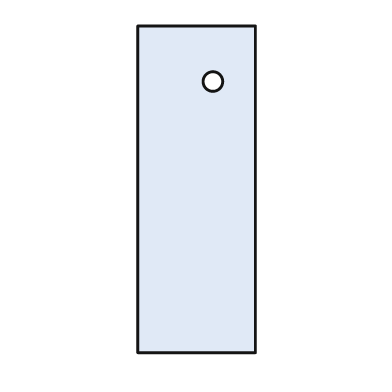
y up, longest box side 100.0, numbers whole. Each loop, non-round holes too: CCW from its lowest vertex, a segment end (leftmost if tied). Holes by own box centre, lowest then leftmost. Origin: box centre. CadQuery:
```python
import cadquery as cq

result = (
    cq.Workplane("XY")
    .moveTo(-18.0, -50.0)
    .lineTo(18.0, -50.0)
    .lineTo(18.0, 50.0)
    .lineTo(-18.0, 50.0)
    .close()
    .moveTo(5.0, 33.0)
    .circle(3.0)
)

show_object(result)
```